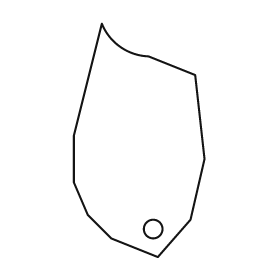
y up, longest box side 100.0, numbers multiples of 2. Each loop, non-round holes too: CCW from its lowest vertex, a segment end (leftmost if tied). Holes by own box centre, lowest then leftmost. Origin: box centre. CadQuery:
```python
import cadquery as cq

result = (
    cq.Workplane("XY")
    .moveTo(8.0, -50.0)
    .lineTo(22.0, -34.0)
    .lineTo(28.0, -8.0)
    .lineTo(24.0, 28.0)
    .lineTo(4.0, 36.0)
    .threePointArc((-8.0, 40.0), (-16.0, 50.0))
    .lineTo(-28.0, 2.0)
    .lineTo(-28.0, -18.0)
    .lineTo(-22.0, -32.0)
    .lineTo(-12.0, -42.0)
    .close()
    .moveTo(6.0, -38.0)
    .circle(4.0)
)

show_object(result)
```